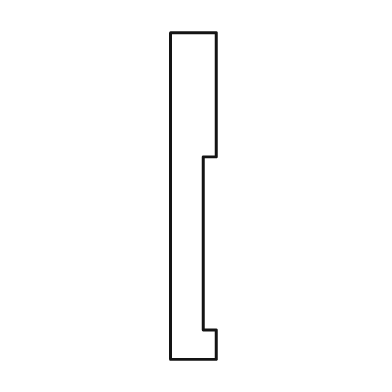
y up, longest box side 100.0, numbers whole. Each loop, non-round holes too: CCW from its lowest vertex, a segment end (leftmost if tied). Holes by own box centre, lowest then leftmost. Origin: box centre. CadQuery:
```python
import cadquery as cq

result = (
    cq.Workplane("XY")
    .moveTo(-7.0, -50.0)
    .lineTo(7.0, -50.0)
    .lineTo(7.0, -41.0)
    .lineTo(3.0, -41.0)
    .lineTo(3.0, 12.0)
    .lineTo(7.0, 12.0)
    .lineTo(7.0, 50.0)
    .lineTo(-7.0, 50.0)
    .close()
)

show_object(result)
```